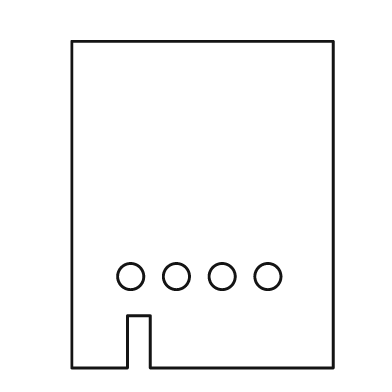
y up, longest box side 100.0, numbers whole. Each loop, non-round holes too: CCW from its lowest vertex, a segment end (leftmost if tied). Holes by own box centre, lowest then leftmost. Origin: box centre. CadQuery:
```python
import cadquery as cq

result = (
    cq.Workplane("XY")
    .moveTo(-40.0, -50.0)
    .lineTo(-23.0, -50.0)
    .lineTo(-23.0, -34.0)
    .lineTo(-16.0, -34.0)
    .lineTo(-16.0, -50.0)
    .lineTo(40.0, -50.0)
    .lineTo(40.0, 50.0)
    .lineTo(-40.0, 50.0)
    .close()
    .moveTo(-22.0, -22.0)
    .circle(4.0)
    .moveTo(-8.0, -22.0)
    .circle(4.0)
    .moveTo(6.0, -22.0)
    .circle(4.0)
    .moveTo(20.0, -22.0)
    .circle(4.0)
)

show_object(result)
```